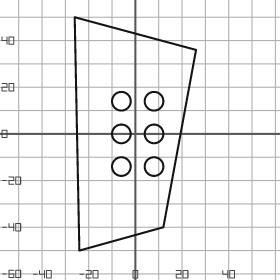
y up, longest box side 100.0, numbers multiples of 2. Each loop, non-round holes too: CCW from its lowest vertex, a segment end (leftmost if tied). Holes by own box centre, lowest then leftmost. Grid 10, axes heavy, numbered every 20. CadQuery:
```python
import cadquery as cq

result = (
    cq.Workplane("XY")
    .moveTo(-24.0, -50.0)
    .lineTo(12.0, -40.0)
    .lineTo(26.0, 36.0)
    .lineTo(-26.0, 50.0)
    .close()
    .moveTo(-6.0, -14.0)
    .circle(4.0)
    .moveTo(8.0, -14.0)
    .circle(4.0)
    .moveTo(-6.0, 0.0)
    .circle(4.0)
    .moveTo(8.0, 0.0)
    .circle(4.0)
    .moveTo(-6.0, 14.0)
    .circle(4.0)
    .moveTo(8.0, 14.0)
    .circle(4.0)
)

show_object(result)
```